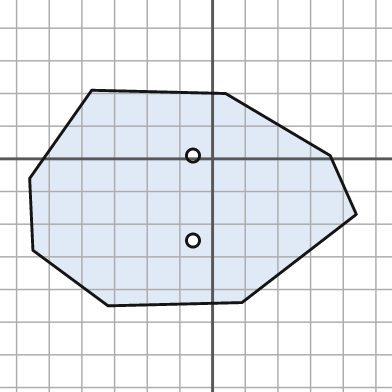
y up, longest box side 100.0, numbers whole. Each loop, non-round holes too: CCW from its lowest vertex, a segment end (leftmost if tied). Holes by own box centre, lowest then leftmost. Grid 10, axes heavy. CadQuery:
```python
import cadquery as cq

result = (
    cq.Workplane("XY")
    .moveTo(-32.0, -45.0)
    .lineTo(9.0, -44.0)
    .lineTo(44.0, -17.0)
    .lineTo(36.0, 1.0)
    .lineTo(4.0, 20.0)
    .lineTo(-37.0, 21.0)
    .lineTo(-56.0, -6.0)
    .lineTo(-55.0, -28.0)
    .close()
    .moveTo(-6.0, -25.0)
    .circle(2.0)
    .moveTo(-6.0, 1.0)
    .circle(2.0)
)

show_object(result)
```